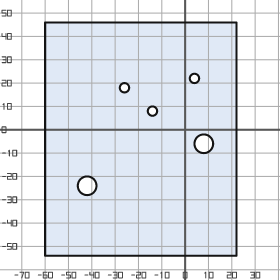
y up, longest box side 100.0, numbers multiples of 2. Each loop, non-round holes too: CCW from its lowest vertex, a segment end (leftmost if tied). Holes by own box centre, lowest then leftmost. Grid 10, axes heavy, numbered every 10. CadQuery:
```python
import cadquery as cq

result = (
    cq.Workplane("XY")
    .moveTo(-60.0, -54.0)
    .lineTo(22.0, -54.0)
    .lineTo(22.0, 46.0)
    .lineTo(-60.0, 46.0)
    .close()
    .moveTo(-42.0, -24.0)
    .circle(4.0)
    .moveTo(8.0, -6.0)
    .circle(4.0)
    .moveTo(-14.0, 8.0)
    .circle(2.0)
    .moveTo(-26.0, 18.0)
    .circle(2.0)
    .moveTo(4.0, 22.0)
    .circle(2.0)
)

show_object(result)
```